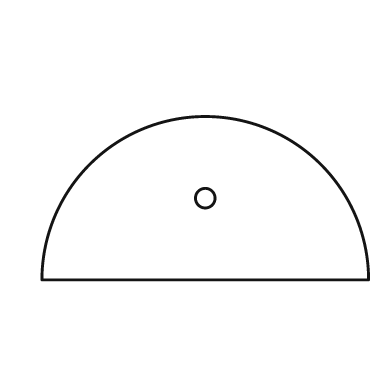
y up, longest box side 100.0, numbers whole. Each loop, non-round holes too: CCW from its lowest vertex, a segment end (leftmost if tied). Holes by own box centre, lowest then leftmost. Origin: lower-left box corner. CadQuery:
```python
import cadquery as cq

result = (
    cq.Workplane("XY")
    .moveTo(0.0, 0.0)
    .lineTo(100.0, 0.0)
    .threePointArc((50.0, 50.0), (0.0, 0.0))
    .close()
    .moveTo(50.0, 25.0)
    .circle(3.0)
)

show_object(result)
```